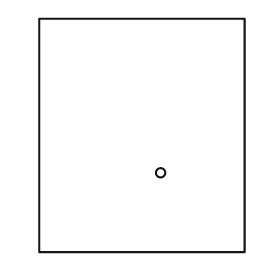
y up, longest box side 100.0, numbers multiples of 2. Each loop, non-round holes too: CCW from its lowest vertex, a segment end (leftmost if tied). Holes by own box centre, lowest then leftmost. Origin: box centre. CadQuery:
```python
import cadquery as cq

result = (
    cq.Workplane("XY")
    .moveTo(-44.0, -50.0)
    .lineTo(44.0, -50.0)
    .lineTo(44.0, 50.0)
    .lineTo(-44.0, 50.0)
    .close()
    .moveTo(8.0, -16.0)
    .circle(2.0)
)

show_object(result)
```